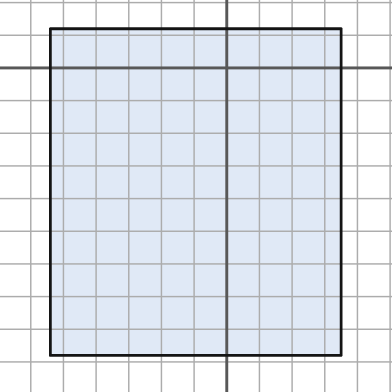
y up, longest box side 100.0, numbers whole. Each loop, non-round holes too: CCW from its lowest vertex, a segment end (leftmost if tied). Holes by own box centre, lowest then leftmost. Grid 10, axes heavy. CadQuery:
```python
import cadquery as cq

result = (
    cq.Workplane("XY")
    .moveTo(-54.0, -88.0)
    .lineTo(35.0, -88.0)
    .lineTo(35.0, 12.0)
    .lineTo(-54.0, 12.0)
    .close()
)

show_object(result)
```